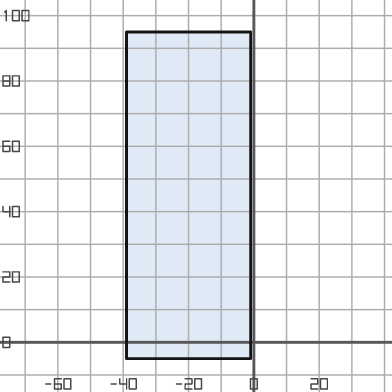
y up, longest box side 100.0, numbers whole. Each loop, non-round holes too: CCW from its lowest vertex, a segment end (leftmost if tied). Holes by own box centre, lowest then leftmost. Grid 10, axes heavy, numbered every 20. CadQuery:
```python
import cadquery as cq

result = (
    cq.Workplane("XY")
    .moveTo(-39.0, -5.0)
    .lineTo(-1.0, -5.0)
    .lineTo(-1.0, 95.0)
    .lineTo(-39.0, 95.0)
    .close()
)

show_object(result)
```